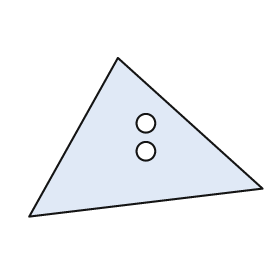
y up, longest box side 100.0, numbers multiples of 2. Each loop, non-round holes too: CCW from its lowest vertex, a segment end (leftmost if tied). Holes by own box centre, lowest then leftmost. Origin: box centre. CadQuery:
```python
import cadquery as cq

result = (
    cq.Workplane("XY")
    .moveTo(-50.0, -34.0)
    .lineTo(50.0, -22.0)
    .lineTo(-12.0, 34.0)
    .close()
    .moveTo(0.0, -6.0)
    .circle(4.0)
    .moveTo(0.0, 6.0)
    .circle(4.0)
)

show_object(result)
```